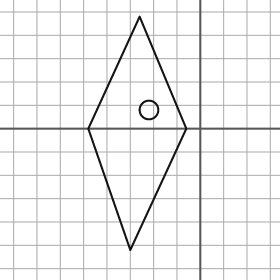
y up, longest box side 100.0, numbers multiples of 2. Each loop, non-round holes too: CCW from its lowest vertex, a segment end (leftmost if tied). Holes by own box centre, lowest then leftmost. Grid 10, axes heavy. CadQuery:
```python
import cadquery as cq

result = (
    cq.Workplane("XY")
    .moveTo(-30.0, -52.0)
    .lineTo(-6.0, 0.0)
    .lineTo(-26.0, 48.0)
    .lineTo(-48.0, 0.0)
    .close()
    .moveTo(-22.0, 8.0)
    .circle(4.0)
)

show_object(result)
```